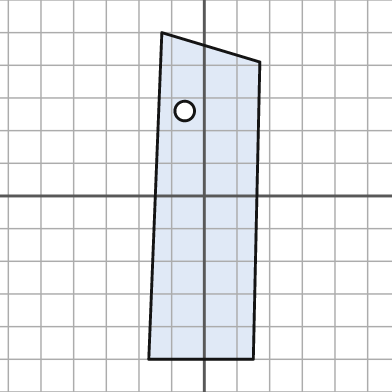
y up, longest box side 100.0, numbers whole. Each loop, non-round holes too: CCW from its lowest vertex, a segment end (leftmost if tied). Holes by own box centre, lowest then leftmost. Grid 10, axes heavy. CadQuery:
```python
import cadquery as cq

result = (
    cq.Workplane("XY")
    .moveTo(-17.0, -50.0)
    .lineTo(15.0, -50.0)
    .lineTo(17.0, 41.0)
    .lineTo(-13.0, 50.0)
    .close()
    .moveTo(-6.0, 26.0)
    .circle(3.0)
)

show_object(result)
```